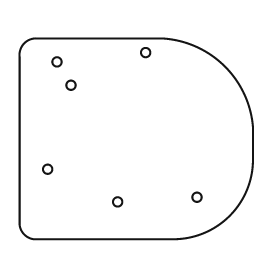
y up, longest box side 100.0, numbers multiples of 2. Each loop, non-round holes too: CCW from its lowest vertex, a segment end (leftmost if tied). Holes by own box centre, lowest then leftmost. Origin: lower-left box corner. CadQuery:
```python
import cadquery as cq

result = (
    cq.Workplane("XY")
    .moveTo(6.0, 0.0)
    .lineTo(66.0, 0.0)
    .threePointArc((90.0, 10.0), (100.0, 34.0))
    .lineTo(100.0, 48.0)
    .threePointArc((88.0, 74.0), (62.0, 86.0))
    .lineTo(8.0, 86.0)
    .threePointArc((2.0, 84.0), (0.0, 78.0))
    .lineTo(0.0, 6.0)
    .threePointArc((2.0, 2.0), (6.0, 0.0))
    .close()
    .moveTo(42.0, 16.0)
    .circle(2.0)
    .moveTo(76.0, 18.0)
    .circle(2.0)
    .moveTo(12.0, 30.0)
    .circle(2.0)
    .moveTo(22.0, 66.0)
    .circle(2.0)
    .moveTo(16.0, 76.0)
    .circle(2.0)
    .moveTo(54.0, 80.0)
    .circle(2.0)
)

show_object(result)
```